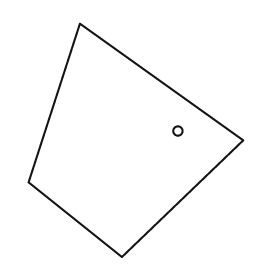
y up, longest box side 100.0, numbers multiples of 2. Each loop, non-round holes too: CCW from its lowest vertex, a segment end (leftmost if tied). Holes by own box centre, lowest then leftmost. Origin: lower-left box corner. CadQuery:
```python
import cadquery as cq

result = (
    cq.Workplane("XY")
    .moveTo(40.0, 0.0)
    .lineTo(92.0, 50.0)
    .lineTo(22.0, 100.0)
    .lineTo(0.0, 32.0)
    .close()
    .moveTo(64.0, 54.0)
    .circle(2.0)
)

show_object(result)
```